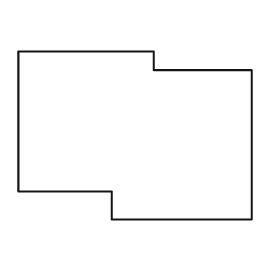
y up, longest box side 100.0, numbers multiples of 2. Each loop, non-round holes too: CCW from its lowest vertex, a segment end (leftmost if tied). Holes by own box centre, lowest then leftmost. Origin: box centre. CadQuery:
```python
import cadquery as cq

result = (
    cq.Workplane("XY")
    .moveTo(-10.0, -36.0)
    .lineTo(50.0, -36.0)
    .lineTo(50.0, 28.0)
    .lineTo(8.0, 28.0)
    .lineTo(8.0, 36.0)
    .lineTo(-50.0, 36.0)
    .lineTo(-50.0, -24.0)
    .lineTo(-10.0, -24.0)
    .close()
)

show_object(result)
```